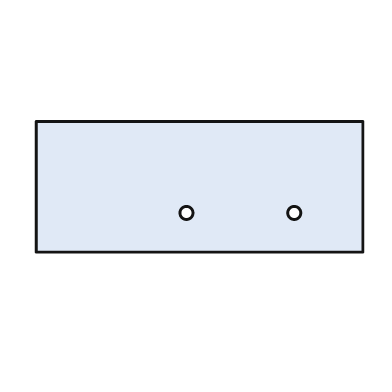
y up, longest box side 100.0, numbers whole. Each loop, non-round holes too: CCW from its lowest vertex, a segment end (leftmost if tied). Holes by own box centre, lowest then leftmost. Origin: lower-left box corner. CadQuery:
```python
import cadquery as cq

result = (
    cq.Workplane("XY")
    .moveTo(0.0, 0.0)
    .lineTo(100.0, 0.0)
    .lineTo(100.0, 40.0)
    .lineTo(0.0, 40.0)
    .close()
    .moveTo(46.0, 12.0)
    .circle(2.0)
    .moveTo(79.0, 12.0)
    .circle(2.0)
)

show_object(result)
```